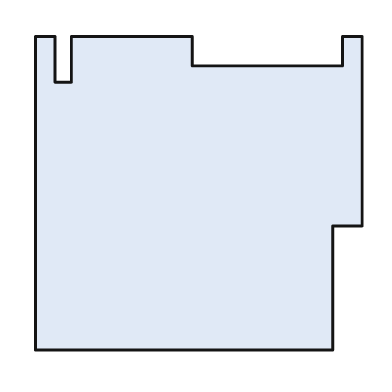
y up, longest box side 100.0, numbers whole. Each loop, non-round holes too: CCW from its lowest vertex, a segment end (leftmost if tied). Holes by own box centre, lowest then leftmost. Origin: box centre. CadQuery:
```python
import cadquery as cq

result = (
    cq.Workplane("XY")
    .moveTo(-50.0, -48.0)
    .lineTo(41.0, -48.0)
    .lineTo(41.0, -10.0)
    .lineTo(50.0, -10.0)
    .lineTo(50.0, 48.0)
    .lineTo(44.0, 48.0)
    .lineTo(44.0, 39.0)
    .lineTo(-2.0, 39.0)
    .lineTo(-2.0, 48.0)
    .lineTo(-39.0, 48.0)
    .lineTo(-39.0, 34.0)
    .lineTo(-44.0, 34.0)
    .lineTo(-44.0, 48.0)
    .lineTo(-50.0, 48.0)
    .close()
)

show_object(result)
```